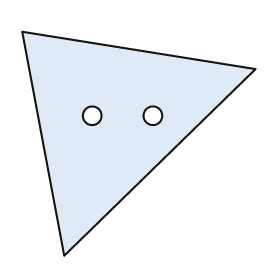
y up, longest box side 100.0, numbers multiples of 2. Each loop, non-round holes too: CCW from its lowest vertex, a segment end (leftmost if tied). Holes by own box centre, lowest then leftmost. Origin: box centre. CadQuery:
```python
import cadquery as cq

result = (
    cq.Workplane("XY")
    .moveTo(-32.0, -48.0)
    .lineTo(50.0, 32.0)
    .lineTo(-50.0, 48.0)
    .close()
    .moveTo(-20.0, 12.0)
    .circle(4.0)
    .moveTo(6.0, 12.0)
    .circle(4.0)
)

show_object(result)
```